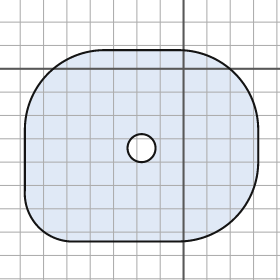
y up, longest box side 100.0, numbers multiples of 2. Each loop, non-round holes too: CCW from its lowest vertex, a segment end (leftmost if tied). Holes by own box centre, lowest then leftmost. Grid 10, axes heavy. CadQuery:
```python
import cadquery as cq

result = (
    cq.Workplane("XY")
    .moveTo(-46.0, -74.0)
    .lineTo(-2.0, -74.0)
    .threePointArc((22.0, -64.0), (32.0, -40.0))
    .lineTo(32.0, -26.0)
    .threePointArc((22.0, -2.0), (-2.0, 8.0))
    .lineTo(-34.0, 8.0)
    .threePointArc((-58.0, -2.0), (-68.0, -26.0))
    .lineTo(-68.0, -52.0)
    .threePointArc((-62.0, -68.0), (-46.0, -74.0))
    .close()
    .moveTo(-18.0, -34.0)
    .circle(6.0)
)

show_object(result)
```